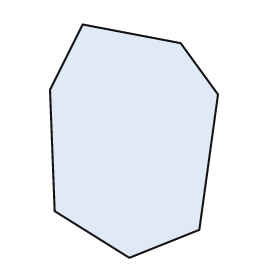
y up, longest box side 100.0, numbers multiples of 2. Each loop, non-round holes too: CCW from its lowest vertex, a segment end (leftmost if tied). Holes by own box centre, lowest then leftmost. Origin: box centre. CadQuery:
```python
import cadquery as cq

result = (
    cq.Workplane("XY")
    .moveTo(-2.0, -50.0)
    .lineTo(28.0, -38.0)
    .lineTo(36.0, 20.0)
    .lineTo(20.0, 42.0)
    .lineTo(-22.0, 50.0)
    .lineTo(-36.0, 22.0)
    .lineTo(-34.0, -30.0)
    .close()
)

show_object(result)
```